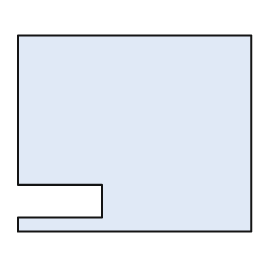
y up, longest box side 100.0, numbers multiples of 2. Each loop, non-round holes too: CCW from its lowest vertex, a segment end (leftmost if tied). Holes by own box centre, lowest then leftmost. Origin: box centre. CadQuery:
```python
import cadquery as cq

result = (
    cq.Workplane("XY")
    .moveTo(-50.0, -42.0)
    .lineTo(50.0, -42.0)
    .lineTo(50.0, 42.0)
    .lineTo(-50.0, 42.0)
    .lineTo(-50.0, -22.0)
    .lineTo(-14.0, -22.0)
    .lineTo(-14.0, -36.0)
    .lineTo(-50.0, -36.0)
    .close()
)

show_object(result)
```